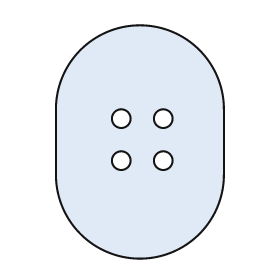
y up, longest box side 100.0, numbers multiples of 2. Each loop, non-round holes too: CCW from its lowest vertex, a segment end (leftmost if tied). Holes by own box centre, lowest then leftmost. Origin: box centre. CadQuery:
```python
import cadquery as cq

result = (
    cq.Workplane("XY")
    .moveTo(-36.0, -14.0)
    .threePointArc((0.0, -50.0), (36.0, -14.0))
    .lineTo(36.0, 14.0)
    .threePointArc((0.0, 50.0), (-36.0, 14.0))
    .close()
    .moveTo(-8.0, -8.0)
    .circle(4.0)
    .moveTo(10.0, -8.0)
    .circle(4.0)
    .moveTo(-8.0, 10.0)
    .circle(4.0)
    .moveTo(10.0, 10.0)
    .circle(4.0)
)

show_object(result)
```